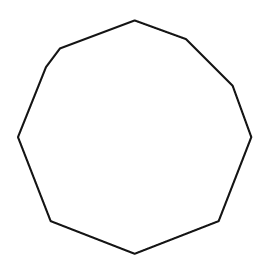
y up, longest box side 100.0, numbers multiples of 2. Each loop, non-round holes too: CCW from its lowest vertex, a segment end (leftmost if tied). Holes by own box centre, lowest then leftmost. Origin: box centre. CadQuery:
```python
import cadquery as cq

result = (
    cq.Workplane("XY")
    .moveTo(0.0, -50.0)
    .lineTo(36.0, -36.0)
    .lineTo(50.0, 0.0)
    .lineTo(42.0, 22.0)
    .lineTo(22.0, 42.0)
    .lineTo(0.0, 50.0)
    .lineTo(-32.0, 38.0)
    .lineTo(-38.0, 30.0)
    .lineTo(-50.0, 0.0)
    .lineTo(-36.0, -36.0)
    .close()
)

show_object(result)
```